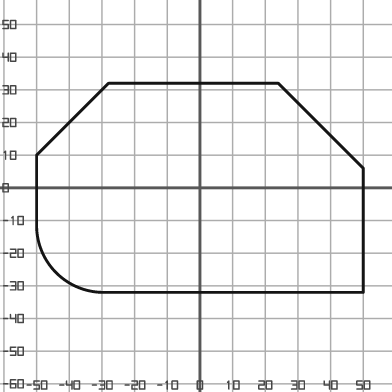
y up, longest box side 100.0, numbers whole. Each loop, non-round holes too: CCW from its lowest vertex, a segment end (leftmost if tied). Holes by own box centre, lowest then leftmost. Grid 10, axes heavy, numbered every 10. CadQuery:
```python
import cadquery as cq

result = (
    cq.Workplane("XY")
    .moveTo(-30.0, -32.0)
    .lineTo(50.0, -32.0)
    .lineTo(50.0, 6.0)
    .lineTo(24.0, 32.0)
    .lineTo(-28.0, 32.0)
    .lineTo(-50.0, 10.0)
    .lineTo(-50.0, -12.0)
    .threePointArc((-44.0, -26.0), (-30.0, -32.0))
    .close()
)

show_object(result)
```